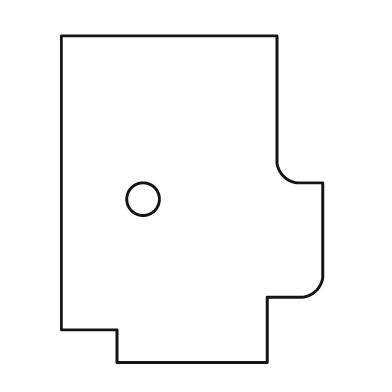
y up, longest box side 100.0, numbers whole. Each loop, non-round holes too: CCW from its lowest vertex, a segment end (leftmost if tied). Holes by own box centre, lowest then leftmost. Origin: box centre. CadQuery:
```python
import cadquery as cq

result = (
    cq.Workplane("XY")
    .moveTo(-23.0, -50.0)
    .lineTo(23.0, -50.0)
    .lineTo(23.0, -30.0)
    .lineTo(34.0, -30.0)
    .threePointArc((38.0, -28.0), (40.0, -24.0))
    .lineTo(40.0, 5.0)
    .lineTo(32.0, 5.0)
    .threePointArc((28.0, 7.0), (26.0, 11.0))
    .lineTo(26.0, 50.0)
    .lineTo(-40.0, 50.0)
    .lineTo(-40.0, -40.0)
    .lineTo(-23.0, -40.0)
    .close()
    .moveTo(-15.0, 0.0)
    .circle(5.0)
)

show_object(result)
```